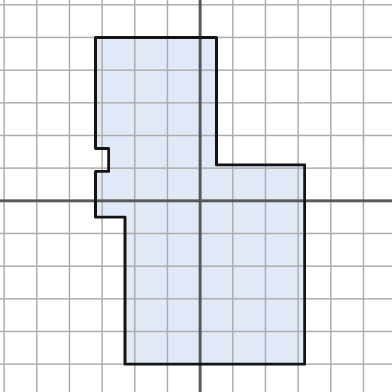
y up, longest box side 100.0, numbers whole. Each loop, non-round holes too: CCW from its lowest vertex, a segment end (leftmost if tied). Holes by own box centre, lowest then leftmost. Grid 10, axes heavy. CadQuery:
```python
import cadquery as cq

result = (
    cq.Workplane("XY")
    .moveTo(-23.0, -50.0)
    .lineTo(32.0, -50.0)
    .lineTo(32.0, 11.0)
    .lineTo(5.0, 11.0)
    .lineTo(5.0, 50.0)
    .lineTo(-32.0, 50.0)
    .lineTo(-32.0, 16.0)
    .lineTo(-28.0, 16.0)
    .lineTo(-28.0, 9.0)
    .lineTo(-32.0, 9.0)
    .lineTo(-32.0, -5.0)
    .lineTo(-23.0, -5.0)
    .close()
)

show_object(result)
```